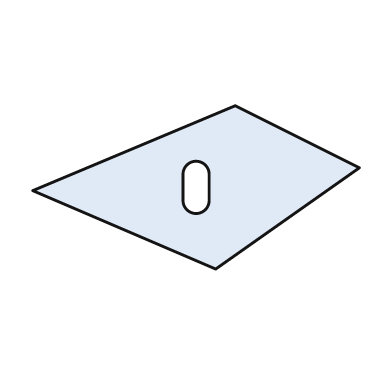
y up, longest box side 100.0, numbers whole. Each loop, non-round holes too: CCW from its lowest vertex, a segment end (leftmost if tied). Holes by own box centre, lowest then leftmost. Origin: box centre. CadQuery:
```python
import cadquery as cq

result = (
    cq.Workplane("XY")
    .moveTo(6.0, -25.0)
    .lineTo(50.0, 6.0)
    .lineTo(12.0, 25.0)
    .lineTo(-50.0, -1.0)
    .close()
    .moveTo(-4.0, -4.0)
    .threePointArc((0.0, -8.0), (4.0, -4.0))
    .lineTo(4.0, 4.0)
    .threePointArc((0.0, 8.0), (-4.0, 4.0))
    .close()
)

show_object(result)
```